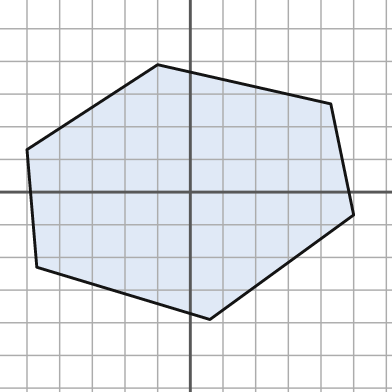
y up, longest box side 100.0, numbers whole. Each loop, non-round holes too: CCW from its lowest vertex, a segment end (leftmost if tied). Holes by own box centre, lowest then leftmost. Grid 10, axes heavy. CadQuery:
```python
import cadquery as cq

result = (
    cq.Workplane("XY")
    .moveTo(6.0, -39.0)
    .lineTo(50.0, -7.0)
    .lineTo(43.0, 27.0)
    .lineTo(-10.0, 39.0)
    .lineTo(-50.0, 13.0)
    .lineTo(-47.0, -23.0)
    .close()
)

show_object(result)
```